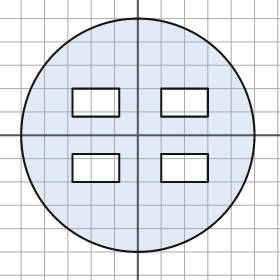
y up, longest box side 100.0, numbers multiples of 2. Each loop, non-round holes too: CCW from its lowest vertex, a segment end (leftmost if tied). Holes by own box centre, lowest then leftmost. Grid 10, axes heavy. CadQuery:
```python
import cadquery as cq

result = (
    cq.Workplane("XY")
    .moveTo(0.0, 0.0)
    .circle(50.0)
    .moveTo(-28.0, -20.0)
    .lineTo(-8.0, -20.0)
    .lineTo(-8.0, -8.0)
    .lineTo(-28.0, -8.0)
    .close()
    .moveTo(10.0, -20.0)
    .lineTo(30.0, -20.0)
    .lineTo(30.0, -8.0)
    .lineTo(10.0, -8.0)
    .close()
    .moveTo(-28.0, 8.0)
    .lineTo(-8.0, 8.0)
    .lineTo(-8.0, 20.0)
    .lineTo(-28.0, 20.0)
    .close()
    .moveTo(10.0, 8.0)
    .lineTo(30.0, 8.0)
    .lineTo(30.0, 20.0)
    .lineTo(10.0, 20.0)
    .close()
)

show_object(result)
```